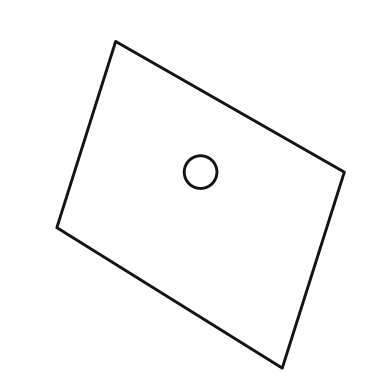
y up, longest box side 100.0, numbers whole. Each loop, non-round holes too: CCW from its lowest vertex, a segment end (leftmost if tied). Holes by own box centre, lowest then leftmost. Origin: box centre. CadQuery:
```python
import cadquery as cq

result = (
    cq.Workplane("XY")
    .moveTo(25.0, -50.0)
    .lineTo(44.0, 10.0)
    .lineTo(-26.0, 50.0)
    .lineTo(-44.0, -7.0)
    .close()
    .moveTo(0.0, 10.0)
    .circle(5.0)
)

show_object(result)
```